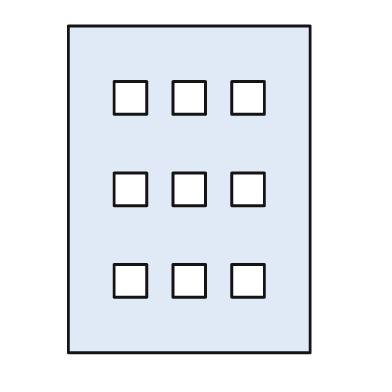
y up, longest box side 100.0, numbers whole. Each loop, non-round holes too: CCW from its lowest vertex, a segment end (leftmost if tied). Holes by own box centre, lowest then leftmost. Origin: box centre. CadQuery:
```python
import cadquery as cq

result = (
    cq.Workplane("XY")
    .moveTo(-37.0, -50.0)
    .lineTo(37.0, -50.0)
    .lineTo(37.0, 50.0)
    .lineTo(-37.0, 50.0)
    .close()
    .moveTo(-23.0, -33.0)
    .lineTo(-13.0, -33.0)
    .lineTo(-13.0, -23.0)
    .lineTo(-23.0, -23.0)
    .close()
    .moveTo(-5.0, -33.0)
    .lineTo(5.0, -33.0)
    .lineTo(5.0, -23.0)
    .lineTo(-5.0, -23.0)
    .close()
    .moveTo(13.0, -33.0)
    .lineTo(23.0, -33.0)
    .lineTo(23.0, -23.0)
    .lineTo(13.0, -23.0)
    .close()
    .moveTo(-23.0, -5.0)
    .lineTo(-13.0, -5.0)
    .lineTo(-13.0, 5.0)
    .lineTo(-23.0, 5.0)
    .close()
    .moveTo(-5.0, -5.0)
    .lineTo(5.0, -5.0)
    .lineTo(5.0, 5.0)
    .lineTo(-5.0, 5.0)
    .close()
    .moveTo(13.0, -5.0)
    .lineTo(23.0, -5.0)
    .lineTo(23.0, 5.0)
    .lineTo(13.0, 5.0)
    .close()
    .moveTo(-23.0, 23.0)
    .lineTo(-13.0, 23.0)
    .lineTo(-13.0, 33.0)
    .lineTo(-23.0, 33.0)
    .close()
    .moveTo(-5.0, 23.0)
    .lineTo(5.0, 23.0)
    .lineTo(5.0, 33.0)
    .lineTo(-5.0, 33.0)
    .close()
    .moveTo(13.0, 23.0)
    .lineTo(23.0, 23.0)
    .lineTo(23.0, 33.0)
    .lineTo(13.0, 33.0)
    .close()
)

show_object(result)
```